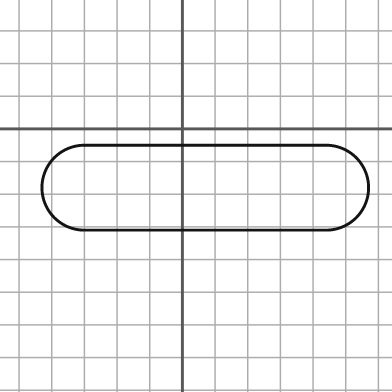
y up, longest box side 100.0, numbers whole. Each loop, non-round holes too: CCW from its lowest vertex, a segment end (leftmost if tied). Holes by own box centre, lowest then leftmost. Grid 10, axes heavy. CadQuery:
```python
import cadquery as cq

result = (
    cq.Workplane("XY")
    .moveTo(-30.0, -31.0)
    .lineTo(44.0, -31.0)
    .threePointArc((57.0, -18.0), (44.0, -5.0))
    .lineTo(-30.0, -5.0)
    .threePointArc((-43.0, -18.0), (-30.0, -31.0))
    .close()
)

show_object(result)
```